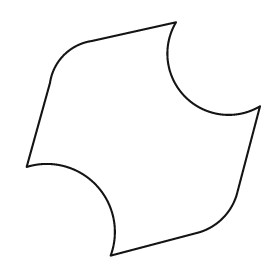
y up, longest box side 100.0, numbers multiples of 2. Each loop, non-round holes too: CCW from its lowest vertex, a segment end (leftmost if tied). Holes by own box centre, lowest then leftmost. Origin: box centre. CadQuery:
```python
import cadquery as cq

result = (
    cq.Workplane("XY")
    .moveTo(-14.0, -50.0)
    .lineTo(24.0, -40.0)
    .threePointArc((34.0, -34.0), (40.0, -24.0))
    .lineTo(50.0, 14.0)
    .threePointArc((18.0, 18.0), (14.0, 50.0))
    .lineTo(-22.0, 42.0)
    .threePointArc((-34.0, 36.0), (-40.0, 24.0))
    .lineTo(-50.0, -12.0)
    .threePointArc((-20.0, -20.0), (-14.0, -50.0))
    .close()
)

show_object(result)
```